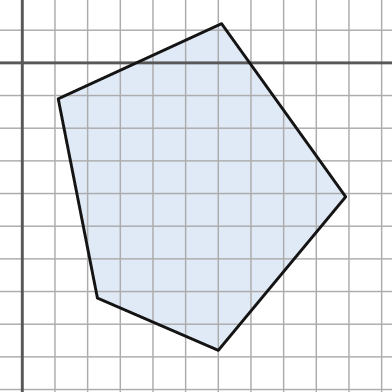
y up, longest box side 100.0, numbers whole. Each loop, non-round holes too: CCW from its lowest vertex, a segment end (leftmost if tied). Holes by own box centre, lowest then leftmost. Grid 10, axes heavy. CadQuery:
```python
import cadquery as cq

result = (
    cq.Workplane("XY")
    .moveTo(60.0, -88.0)
    .lineTo(99.0, -41.0)
    .lineTo(61.0, 12.0)
    .lineTo(11.0, -11.0)
    .lineTo(23.0, -72.0)
    .close()
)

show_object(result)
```